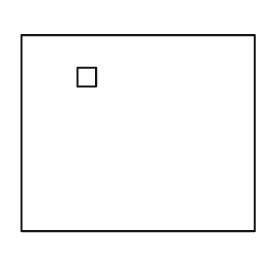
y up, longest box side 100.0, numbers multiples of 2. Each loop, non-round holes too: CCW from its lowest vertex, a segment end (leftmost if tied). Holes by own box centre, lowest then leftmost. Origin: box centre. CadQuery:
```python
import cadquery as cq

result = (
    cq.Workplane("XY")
    .moveTo(-50.0, -42.0)
    .lineTo(50.0, -42.0)
    .lineTo(50.0, 42.0)
    .lineTo(-50.0, 42.0)
    .close()
    .moveTo(-26.0, 20.0)
    .lineTo(-18.0, 20.0)
    .lineTo(-18.0, 28.0)
    .lineTo(-26.0, 28.0)
    .close()
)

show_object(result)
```